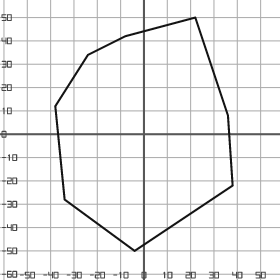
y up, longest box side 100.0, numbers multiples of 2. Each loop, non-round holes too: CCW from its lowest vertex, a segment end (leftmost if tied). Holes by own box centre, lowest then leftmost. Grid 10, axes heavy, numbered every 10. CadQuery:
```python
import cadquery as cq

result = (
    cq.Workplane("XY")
    .moveTo(-4.0, -50.0)
    .lineTo(38.0, -22.0)
    .lineTo(36.0, 8.0)
    .lineTo(22.0, 50.0)
    .lineTo(-8.0, 42.0)
    .lineTo(-24.0, 34.0)
    .lineTo(-38.0, 12.0)
    .lineTo(-34.0, -28.0)
    .close()
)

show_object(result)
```